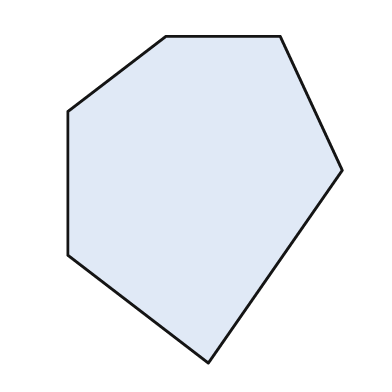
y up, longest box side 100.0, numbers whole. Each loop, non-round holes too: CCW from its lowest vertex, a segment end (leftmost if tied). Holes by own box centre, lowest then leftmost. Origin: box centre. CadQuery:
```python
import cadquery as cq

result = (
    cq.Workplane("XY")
    .moveTo(1.0, -50.0)
    .lineTo(42.0, 9.0)
    .lineTo(23.0, 50.0)
    .lineTo(-12.0, 50.0)
    .lineTo(-42.0, 27.0)
    .lineTo(-42.0, -17.0)
    .close()
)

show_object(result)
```